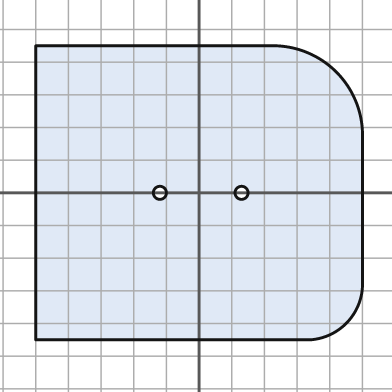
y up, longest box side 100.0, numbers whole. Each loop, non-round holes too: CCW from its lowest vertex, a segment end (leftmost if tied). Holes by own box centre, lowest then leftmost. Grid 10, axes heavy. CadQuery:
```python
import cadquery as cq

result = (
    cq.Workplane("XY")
    .moveTo(-50.0, -45.0)
    .lineTo(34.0, -45.0)
    .threePointArc((45.0, -40.0), (50.0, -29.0))
    .lineTo(50.0, 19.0)
    .threePointArc((42.0, 37.0), (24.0, 45.0))
    .lineTo(-50.0, 45.0)
    .close()
    .moveTo(-12.0, 0.0)
    .circle(2.0)
    .moveTo(13.0, 0.0)
    .circle(2.0)
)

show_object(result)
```